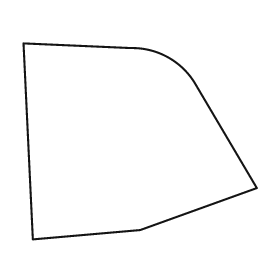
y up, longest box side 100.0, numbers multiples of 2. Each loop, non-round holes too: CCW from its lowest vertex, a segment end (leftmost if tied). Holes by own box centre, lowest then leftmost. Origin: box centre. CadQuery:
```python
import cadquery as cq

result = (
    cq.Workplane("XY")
    .moveTo(-46.0, -42.0)
    .lineTo(0.0, -38.0)
    .lineTo(50.0, -20.0)
    .lineTo(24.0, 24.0)
    .threePointArc((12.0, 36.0), (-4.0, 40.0))
    .lineTo(-50.0, 42.0)
    .close()
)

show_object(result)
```